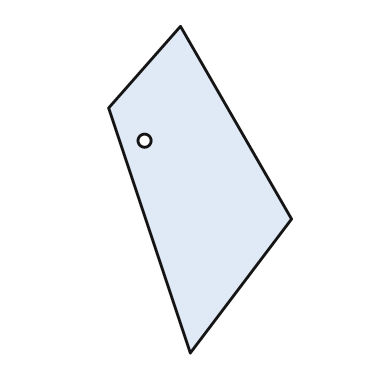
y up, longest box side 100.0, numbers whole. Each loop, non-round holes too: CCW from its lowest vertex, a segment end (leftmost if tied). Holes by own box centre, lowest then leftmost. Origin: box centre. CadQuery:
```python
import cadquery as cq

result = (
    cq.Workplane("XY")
    .moveTo(-3.0, -50.0)
    .lineTo(28.0, -9.0)
    .lineTo(-6.0, 50.0)
    .lineTo(-28.0, 25.0)
    .close()
    .moveTo(-17.0, 15.0)
    .circle(2.0)
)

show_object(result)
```